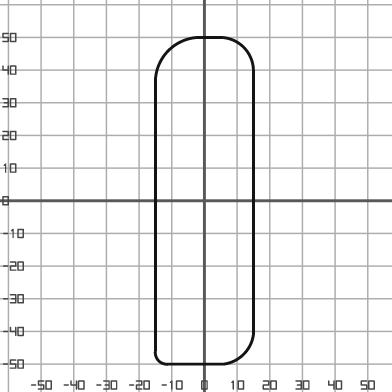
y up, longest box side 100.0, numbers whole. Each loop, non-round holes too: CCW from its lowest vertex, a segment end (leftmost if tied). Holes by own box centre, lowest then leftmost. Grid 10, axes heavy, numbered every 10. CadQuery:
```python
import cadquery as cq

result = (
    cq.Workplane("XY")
    .moveTo(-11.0, -50.0)
    .lineTo(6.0, -50.0)
    .threePointArc((12.0, -47.0), (15.0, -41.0))
    .lineTo(15.0, 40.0)
    .threePointArc((12.0, 47.0), (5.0, 50.0))
    .lineTo(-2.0, 50.0)
    .threePointArc((-11.0, 46.0), (-15.0, 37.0))
    .lineTo(-15.0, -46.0)
    .threePointArc((-14.0, -49.0), (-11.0, -50.0))
    .close()
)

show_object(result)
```